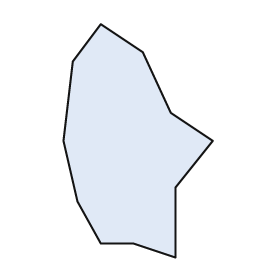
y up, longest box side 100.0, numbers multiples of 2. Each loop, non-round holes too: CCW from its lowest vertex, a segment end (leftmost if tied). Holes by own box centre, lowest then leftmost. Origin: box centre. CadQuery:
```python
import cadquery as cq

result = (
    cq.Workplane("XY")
    .moveTo(16.0, -50.0)
    .lineTo(16.0, -20.0)
    .lineTo(32.0, 0.0)
    .lineTo(14.0, 12.0)
    .lineTo(2.0, 38.0)
    .lineTo(-16.0, 50.0)
    .lineTo(-28.0, 34.0)
    .lineTo(-32.0, 0.0)
    .lineTo(-26.0, -26.0)
    .lineTo(-16.0, -44.0)
    .lineTo(-2.0, -44.0)
    .close()
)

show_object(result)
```